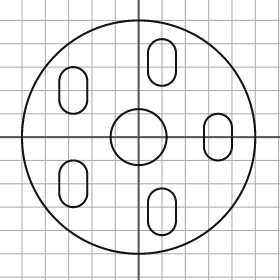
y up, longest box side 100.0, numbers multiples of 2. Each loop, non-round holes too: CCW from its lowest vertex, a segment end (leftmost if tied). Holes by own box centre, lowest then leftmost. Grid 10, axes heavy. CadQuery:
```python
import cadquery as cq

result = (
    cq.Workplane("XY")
    .moveTo(0.0, 0.0)
    .circle(50.0)
    .moveTo(4.0, -36.0)
    .threePointArc((10.0, -42.0), (16.0, -36.0))
    .lineTo(16.0, -28.0)
    .threePointArc((10.0, -22.0), (4.0, -28.0))
    .close()
    .moveTo(-34.0, -24.0)
    .threePointArc((-28.0, -30.0), (-22.0, -24.0))
    .lineTo(-22.0, -16.0)
    .threePointArc((-28.0, -10.0), (-34.0, -16.0))
    .close()
    .moveTo(0.0, 0.0)
    .circle(12.0)
    .moveTo(28.0, -4.0)
    .threePointArc((34.0, -10.0), (40.0, -4.0))
    .lineTo(40.0, 4.0)
    .threePointArc((34.0, 10.0), (28.0, 4.0))
    .close()
    .moveTo(-34.0, 16.0)
    .threePointArc((-28.0, 10.0), (-22.0, 16.0))
    .lineTo(-22.0, 24.0)
    .threePointArc((-28.0, 30.0), (-34.0, 24.0))
    .close()
    .moveTo(4.0, 28.0)
    .threePointArc((10.0, 22.0), (16.0, 28.0))
    .lineTo(16.0, 36.0)
    .threePointArc((10.0, 42.0), (4.0, 36.0))
    .close()
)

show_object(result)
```